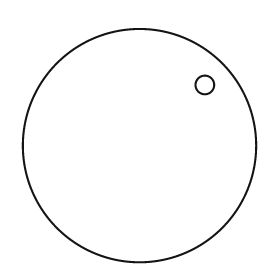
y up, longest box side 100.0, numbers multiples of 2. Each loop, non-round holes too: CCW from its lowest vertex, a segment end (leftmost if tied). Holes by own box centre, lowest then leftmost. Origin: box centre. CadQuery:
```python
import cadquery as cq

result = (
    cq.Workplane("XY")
    .moveTo(0.0, 0.0)
    .circle(50.0)
    .moveTo(28.0, 26.0)
    .circle(4.0)
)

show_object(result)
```